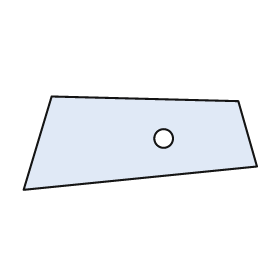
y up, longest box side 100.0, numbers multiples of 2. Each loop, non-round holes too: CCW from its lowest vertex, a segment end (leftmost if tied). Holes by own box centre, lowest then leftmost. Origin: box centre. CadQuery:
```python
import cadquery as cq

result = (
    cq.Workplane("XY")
    .moveTo(-50.0, -20.0)
    .lineTo(50.0, -10.0)
    .lineTo(42.0, 18.0)
    .lineTo(-38.0, 20.0)
    .close()
    .moveTo(10.0, 2.0)
    .circle(4.0)
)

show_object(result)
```